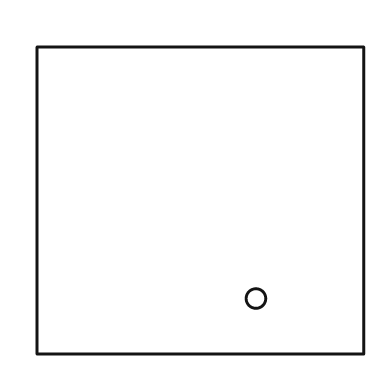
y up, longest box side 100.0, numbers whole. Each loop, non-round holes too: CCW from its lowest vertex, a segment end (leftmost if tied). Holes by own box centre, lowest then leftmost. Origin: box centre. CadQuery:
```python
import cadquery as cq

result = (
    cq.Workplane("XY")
    .moveTo(-50.0, -47.0)
    .lineTo(50.0, -47.0)
    .lineTo(50.0, 47.0)
    .lineTo(-50.0, 47.0)
    .close()
    .moveTo(17.0, -30.0)
    .circle(3.0)
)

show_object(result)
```